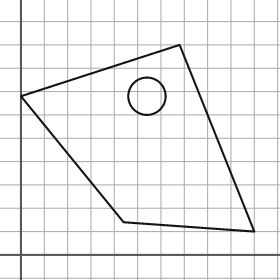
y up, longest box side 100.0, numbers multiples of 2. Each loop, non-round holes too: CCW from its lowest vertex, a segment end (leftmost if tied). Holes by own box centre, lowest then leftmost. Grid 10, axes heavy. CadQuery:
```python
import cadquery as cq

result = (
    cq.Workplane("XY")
    .moveTo(100.0, 10.0)
    .lineTo(68.0, 90.0)
    .lineTo(0.0, 68.0)
    .lineTo(44.0, 14.0)
    .close()
    .moveTo(54.0, 68.0)
    .circle(8.0)
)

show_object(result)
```